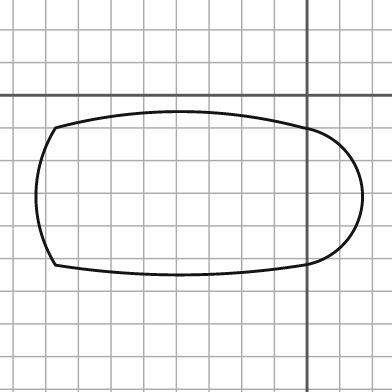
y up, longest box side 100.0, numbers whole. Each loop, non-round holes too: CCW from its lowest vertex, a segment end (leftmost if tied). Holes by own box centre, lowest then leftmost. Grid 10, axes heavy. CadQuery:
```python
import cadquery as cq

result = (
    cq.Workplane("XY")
    .moveTo(-77.0, -52.0)
    .threePointArc((-39.0, -55.0), (-1.0, -52.0))
    .threePointArc((17.0, -31.0), (-1.0, -10.0))
    .threePointArc((-39.0, -5.0), (-77.0, -10.0))
    .threePointArc((-83.0, -31.0), (-77.0, -52.0))
    .close()
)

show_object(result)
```